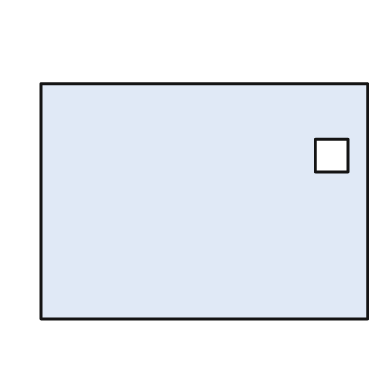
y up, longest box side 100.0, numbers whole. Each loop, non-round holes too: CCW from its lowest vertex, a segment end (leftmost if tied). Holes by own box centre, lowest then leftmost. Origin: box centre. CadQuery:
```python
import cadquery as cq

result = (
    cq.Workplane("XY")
    .moveTo(-50.0, -36.0)
    .lineTo(50.0, -36.0)
    .lineTo(50.0, 36.0)
    .lineTo(-50.0, 36.0)
    .close()
    .moveTo(34.0, 9.0)
    .lineTo(44.0, 9.0)
    .lineTo(44.0, 19.0)
    .lineTo(34.0, 19.0)
    .close()
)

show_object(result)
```